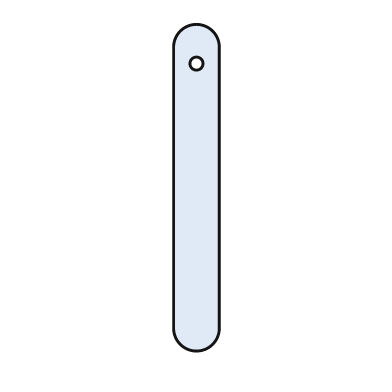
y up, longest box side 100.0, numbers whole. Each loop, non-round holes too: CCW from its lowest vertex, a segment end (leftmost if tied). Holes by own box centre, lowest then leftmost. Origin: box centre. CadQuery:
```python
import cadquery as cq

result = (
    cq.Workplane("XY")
    .moveTo(-7.0, -43.0)
    .threePointArc((0.0, -50.0), (7.0, -43.0))
    .lineTo(7.0, 43.0)
    .threePointArc((0.0, 50.0), (-7.0, 43.0))
    .close()
    .moveTo(0.0, 38.0)
    .circle(2.0)
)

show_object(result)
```